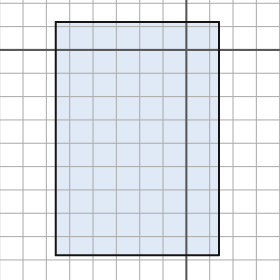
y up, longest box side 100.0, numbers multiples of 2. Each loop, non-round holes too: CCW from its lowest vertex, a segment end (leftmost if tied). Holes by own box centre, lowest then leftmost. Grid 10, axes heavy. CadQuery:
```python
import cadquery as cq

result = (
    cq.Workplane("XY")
    .moveTo(-56.0, -88.0)
    .lineTo(14.0, -88.0)
    .lineTo(14.0, 12.0)
    .lineTo(-56.0, 12.0)
    .close()
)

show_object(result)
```